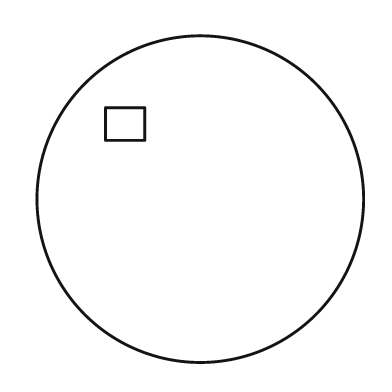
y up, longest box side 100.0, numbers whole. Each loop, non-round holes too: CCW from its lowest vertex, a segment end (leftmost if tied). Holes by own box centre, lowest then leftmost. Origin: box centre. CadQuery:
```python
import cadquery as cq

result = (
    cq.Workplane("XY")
    .moveTo(0.0, 0.0)
    .circle(50.0)
    .moveTo(-29.0, 18.0)
    .lineTo(-17.0, 18.0)
    .lineTo(-17.0, 28.0)
    .lineTo(-29.0, 28.0)
    .close()
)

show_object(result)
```